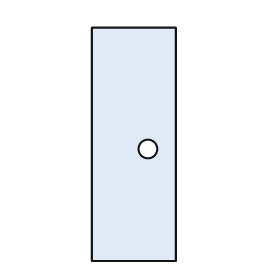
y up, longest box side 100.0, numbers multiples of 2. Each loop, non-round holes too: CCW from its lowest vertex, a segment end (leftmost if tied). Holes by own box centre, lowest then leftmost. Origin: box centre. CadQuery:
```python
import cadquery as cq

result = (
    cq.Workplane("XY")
    .moveTo(-18.0, -50.0)
    .lineTo(18.0, -50.0)
    .lineTo(18.0, 50.0)
    .lineTo(-18.0, 50.0)
    .close()
    .moveTo(6.0, -2.0)
    .circle(4.0)
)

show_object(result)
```